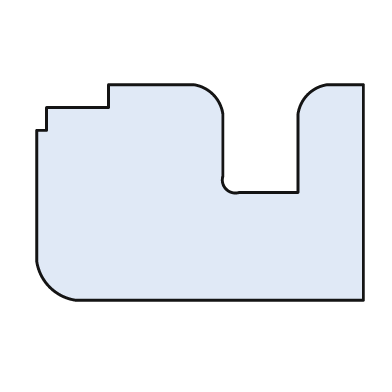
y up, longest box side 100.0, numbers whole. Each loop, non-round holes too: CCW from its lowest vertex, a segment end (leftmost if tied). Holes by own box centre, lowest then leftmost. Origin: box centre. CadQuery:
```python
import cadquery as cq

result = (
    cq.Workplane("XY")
    .moveTo(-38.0, -33.0)
    .lineTo(50.0, -33.0)
    .lineTo(50.0, 33.0)
    .lineTo(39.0, 33.0)
    .threePointArc((33.0, 30.0), (30.0, 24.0))
    .lineTo(30.0, 0.0)
    .lineTo(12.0, 0.0)
    .threePointArc((8.0, 1.0), (7.0, 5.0))
    .lineTo(7.0, 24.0)
    .threePointArc((4.0, 30.0), (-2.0, 33.0))
    .lineTo(-28.0, 33.0)
    .lineTo(-28.0, 26.0)
    .lineTo(-47.0, 26.0)
    .lineTo(-47.0, 19.0)
    .lineTo(-50.0, 19.0)
    .lineTo(-50.0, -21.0)
    .threePointArc((-46.0, -29.0), (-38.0, -33.0))
    .close()
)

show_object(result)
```